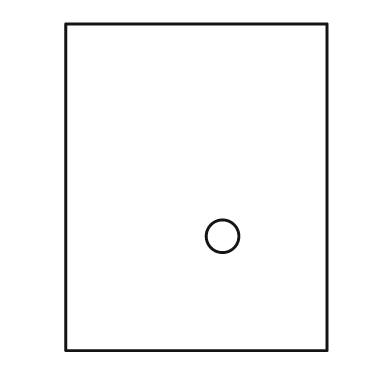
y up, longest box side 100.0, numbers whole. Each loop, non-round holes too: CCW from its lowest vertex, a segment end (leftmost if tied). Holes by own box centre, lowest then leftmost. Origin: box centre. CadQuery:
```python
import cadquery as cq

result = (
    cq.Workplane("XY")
    .moveTo(-40.0, -50.0)
    .lineTo(40.0, -50.0)
    .lineTo(40.0, 50.0)
    .lineTo(-40.0, 50.0)
    .close()
    .moveTo(8.0, -15.0)
    .circle(5.0)
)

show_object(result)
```